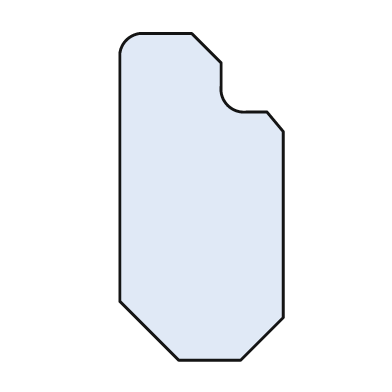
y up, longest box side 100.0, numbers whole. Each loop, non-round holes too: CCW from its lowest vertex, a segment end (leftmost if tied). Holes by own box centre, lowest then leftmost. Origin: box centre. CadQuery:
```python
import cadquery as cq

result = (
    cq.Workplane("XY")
    .moveTo(-7.0, -50.0)
    .lineTo(12.0, -50.0)
    .lineTo(25.0, -37.0)
    .lineTo(25.0, 20.0)
    .lineTo(20.0, 26.0)
    .lineTo(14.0, 26.0)
    .threePointArc((8.0, 28.0), (6.0, 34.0))
    .lineTo(6.0, 41.0)
    .lineTo(-3.0, 50.0)
    .lineTo(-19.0, 50.0)
    .threePointArc((-23.0, 48.0), (-25.0, 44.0))
    .lineTo(-25.0, -32.0)
    .close()
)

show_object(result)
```